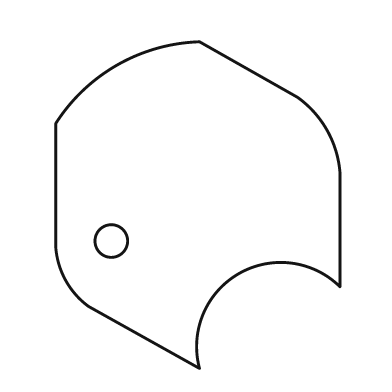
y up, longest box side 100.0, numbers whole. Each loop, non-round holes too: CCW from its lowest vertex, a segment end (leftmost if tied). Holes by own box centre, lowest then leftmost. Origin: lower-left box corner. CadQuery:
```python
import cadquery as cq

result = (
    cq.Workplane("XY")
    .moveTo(44.0, 0.0)
    .threePointArc((56.0, 29.0), (87.0, 25.0))
    .lineTo(87.0, 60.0)
    .threePointArc((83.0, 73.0), (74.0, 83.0))
    .lineTo(44.0, 100.0)
    .threePointArc((19.0, 93.0), (0.0, 75.0))
    .lineTo(0.0, 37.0)
    .threePointArc((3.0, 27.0), (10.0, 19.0))
    .close()
    .moveTo(17.0, 39.0)
    .circle(5.0)
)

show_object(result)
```